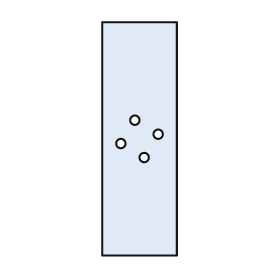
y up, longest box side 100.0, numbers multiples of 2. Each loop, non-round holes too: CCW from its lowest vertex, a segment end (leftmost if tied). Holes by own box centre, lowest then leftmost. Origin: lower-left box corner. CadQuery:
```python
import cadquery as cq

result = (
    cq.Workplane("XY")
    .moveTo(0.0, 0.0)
    .lineTo(32.0, 0.0)
    .lineTo(32.0, 100.0)
    .lineTo(0.0, 100.0)
    .close()
    .moveTo(18.0, 42.0)
    .circle(2.0)
    .moveTo(8.0, 48.0)
    .circle(2.0)
    .moveTo(24.0, 52.0)
    .circle(2.0)
    .moveTo(14.0, 58.0)
    .circle(2.0)
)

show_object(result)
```